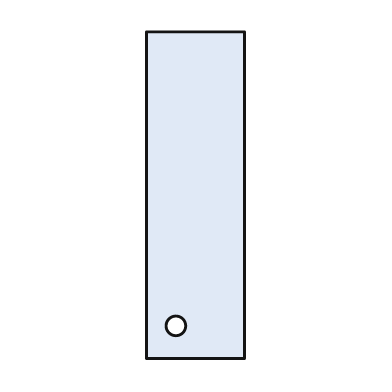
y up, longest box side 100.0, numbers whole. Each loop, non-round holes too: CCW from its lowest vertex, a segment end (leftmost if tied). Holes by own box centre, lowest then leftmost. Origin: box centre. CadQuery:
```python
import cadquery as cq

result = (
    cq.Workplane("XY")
    .moveTo(-15.0, -50.0)
    .lineTo(15.0, -50.0)
    .lineTo(15.0, 50.0)
    .lineTo(-15.0, 50.0)
    .close()
    .moveTo(-6.0, -40.0)
    .circle(3.0)
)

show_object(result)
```